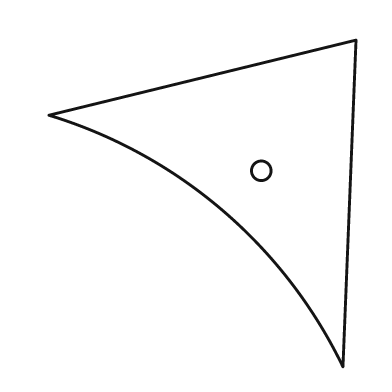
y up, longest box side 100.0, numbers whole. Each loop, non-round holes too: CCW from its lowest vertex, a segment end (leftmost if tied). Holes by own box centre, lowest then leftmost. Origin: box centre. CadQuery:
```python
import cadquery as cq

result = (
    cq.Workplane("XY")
    .moveTo(43.0, -50.0)
    .lineTo(47.0, 50.0)
    .lineTo(-47.0, 27.0)
    .threePointArc((6.0, -2.0), (43.0, -50.0))
    .close()
    .moveTo(18.0, 10.0)
    .circle(3.0)
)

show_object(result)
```